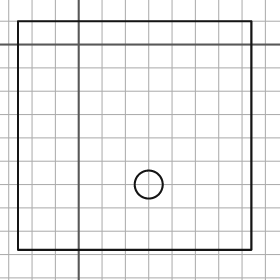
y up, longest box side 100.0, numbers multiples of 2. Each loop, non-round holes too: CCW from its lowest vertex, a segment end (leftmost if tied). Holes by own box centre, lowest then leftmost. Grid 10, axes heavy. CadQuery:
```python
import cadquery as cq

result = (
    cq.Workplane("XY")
    .moveTo(-26.0, -88.0)
    .lineTo(74.0, -88.0)
    .lineTo(74.0, 10.0)
    .lineTo(-26.0, 10.0)
    .close()
    .moveTo(30.0, -60.0)
    .circle(6.0)
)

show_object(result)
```